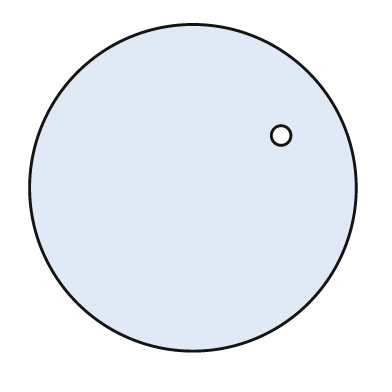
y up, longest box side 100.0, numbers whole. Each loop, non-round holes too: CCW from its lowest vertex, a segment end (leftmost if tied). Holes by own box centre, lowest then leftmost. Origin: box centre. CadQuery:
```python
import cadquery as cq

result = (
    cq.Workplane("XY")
    .moveTo(0.0, 0.0)
    .circle(50.0)
    .moveTo(27.0, 16.0)
    .circle(3.0)
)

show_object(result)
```